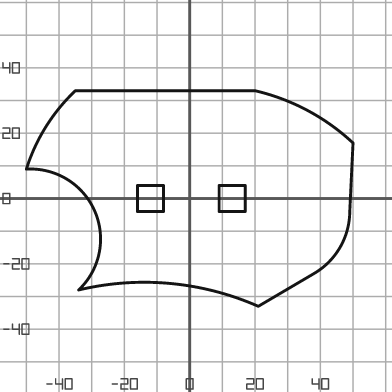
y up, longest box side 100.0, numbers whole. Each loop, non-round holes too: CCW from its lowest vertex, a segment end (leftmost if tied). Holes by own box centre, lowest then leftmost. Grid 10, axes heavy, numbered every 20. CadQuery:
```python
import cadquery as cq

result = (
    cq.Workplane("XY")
    .moveTo(21.0, -33.0)
    .lineTo(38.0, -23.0)
    .threePointArc((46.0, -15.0), (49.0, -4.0))
    .lineTo(50.0, 17.0)
    .threePointArc((36.0, 27.0), (20.0, 33.0))
    .lineTo(-35.0, 33.0)
    .threePointArc((-44.0, 22.0), (-50.0, 9.0))
    .threePointArc((-29.0, -4.0), (-34.0, -28.0))
    .threePointArc((-6.0, -26.0), (21.0, -33.0))
    .close()
    .moveTo(-16.0, -4.0)
    .lineTo(-8.0, -4.0)
    .lineTo(-8.0, 4.0)
    .lineTo(-16.0, 4.0)
    .close()
    .moveTo(9.0, -4.0)
    .lineTo(17.0, -4.0)
    .lineTo(17.0, 4.0)
    .lineTo(9.0, 4.0)
    .close()
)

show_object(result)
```